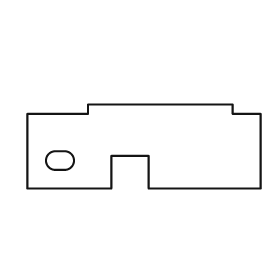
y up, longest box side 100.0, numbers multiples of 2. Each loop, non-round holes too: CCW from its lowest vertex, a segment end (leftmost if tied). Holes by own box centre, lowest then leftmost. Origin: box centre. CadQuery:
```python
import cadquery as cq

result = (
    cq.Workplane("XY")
    .moveTo(-50.0, -18.0)
    .lineTo(-14.0, -18.0)
    .lineTo(-14.0, -4.0)
    .lineTo(2.0, -4.0)
    .lineTo(2.0, -18.0)
    .lineTo(50.0, -18.0)
    .lineTo(50.0, 14.0)
    .lineTo(38.0, 14.0)
    .lineTo(38.0, 18.0)
    .lineTo(-24.0, 18.0)
    .lineTo(-24.0, 14.0)
    .lineTo(-50.0, 14.0)
    .close()
    .moveTo(-38.0, -10.0)
    .lineTo(-34.0, -10.0)
    .threePointArc((-30.0, -6.0), (-34.0, -2.0))
    .lineTo(-38.0, -2.0)
    .threePointArc((-42.0, -6.0), (-38.0, -10.0))
    .close()
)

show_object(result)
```